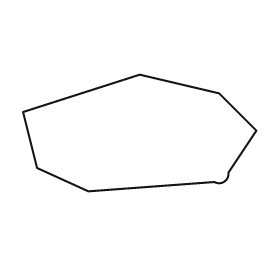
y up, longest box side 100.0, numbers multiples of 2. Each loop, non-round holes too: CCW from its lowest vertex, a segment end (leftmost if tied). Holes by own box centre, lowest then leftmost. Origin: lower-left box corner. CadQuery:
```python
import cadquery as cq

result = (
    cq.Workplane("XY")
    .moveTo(28.0, 0.0)
    .lineTo(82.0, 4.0)
    .threePointArc((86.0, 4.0), (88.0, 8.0))
    .lineTo(100.0, 26.0)
    .lineTo(84.0, 42.0)
    .lineTo(50.0, 50.0)
    .lineTo(0.0, 34.0)
    .lineTo(6.0, 10.0)
    .close()
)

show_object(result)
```